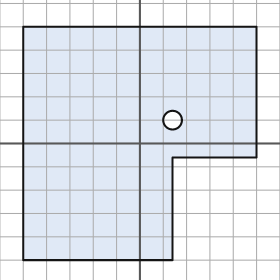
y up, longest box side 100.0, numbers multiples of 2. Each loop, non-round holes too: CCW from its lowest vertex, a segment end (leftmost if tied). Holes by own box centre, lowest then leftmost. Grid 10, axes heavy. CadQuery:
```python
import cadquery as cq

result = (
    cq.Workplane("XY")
    .moveTo(-50.0, -50.0)
    .lineTo(14.0, -50.0)
    .lineTo(14.0, -6.0)
    .lineTo(50.0, -6.0)
    .lineTo(50.0, 50.0)
    .lineTo(-50.0, 50.0)
    .close()
    .moveTo(14.0, 10.0)
    .circle(4.0)
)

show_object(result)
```